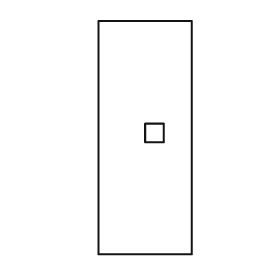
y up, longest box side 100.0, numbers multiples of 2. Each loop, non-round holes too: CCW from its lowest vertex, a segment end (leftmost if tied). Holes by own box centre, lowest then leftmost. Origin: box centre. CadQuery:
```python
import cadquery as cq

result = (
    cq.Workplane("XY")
    .moveTo(-20.0, -50.0)
    .lineTo(20.0, -50.0)
    .lineTo(20.0, 50.0)
    .lineTo(-20.0, 50.0)
    .close()
    .moveTo(0.0, -2.0)
    .lineTo(8.0, -2.0)
    .lineTo(8.0, 6.0)
    .lineTo(0.0, 6.0)
    .close()
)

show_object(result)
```